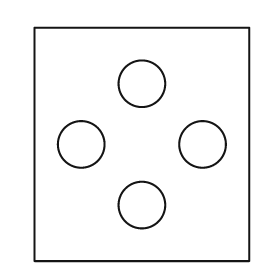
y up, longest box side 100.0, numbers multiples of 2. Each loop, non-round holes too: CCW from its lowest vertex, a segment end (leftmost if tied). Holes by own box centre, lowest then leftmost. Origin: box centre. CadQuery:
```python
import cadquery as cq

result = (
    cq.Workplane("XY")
    .moveTo(-46.0, -50.0)
    .lineTo(46.0, -50.0)
    .lineTo(46.0, 50.0)
    .lineTo(-46.0, 50.0)
    .close()
    .moveTo(0.0, -26.0)
    .circle(10.0)
    .moveTo(-26.0, 0.0)
    .circle(10.0)
    .moveTo(26.0, 0.0)
    .circle(10.0)
    .moveTo(0.0, 26.0)
    .circle(10.0)
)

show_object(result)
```